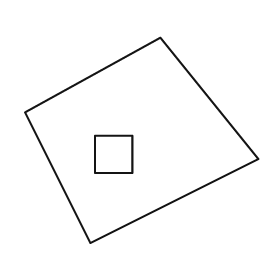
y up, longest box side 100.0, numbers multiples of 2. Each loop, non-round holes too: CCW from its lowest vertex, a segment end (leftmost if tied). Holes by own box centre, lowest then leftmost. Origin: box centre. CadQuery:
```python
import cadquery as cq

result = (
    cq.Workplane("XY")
    .moveTo(-22.0, -44.0)
    .lineTo(50.0, -8.0)
    .lineTo(8.0, 44.0)
    .lineTo(-50.0, 12.0)
    .close()
    .moveTo(-20.0, -14.0)
    .lineTo(-4.0, -14.0)
    .lineTo(-4.0, 2.0)
    .lineTo(-20.0, 2.0)
    .close()
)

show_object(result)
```